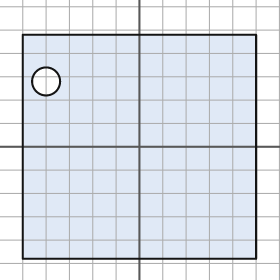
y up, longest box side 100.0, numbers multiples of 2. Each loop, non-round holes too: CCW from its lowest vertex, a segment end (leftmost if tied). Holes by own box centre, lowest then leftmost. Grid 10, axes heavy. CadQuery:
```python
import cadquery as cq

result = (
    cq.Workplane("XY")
    .moveTo(-50.0, -48.0)
    .lineTo(50.0, -48.0)
    .lineTo(50.0, 48.0)
    .lineTo(-50.0, 48.0)
    .close()
    .moveTo(-40.0, 28.0)
    .circle(6.0)
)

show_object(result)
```